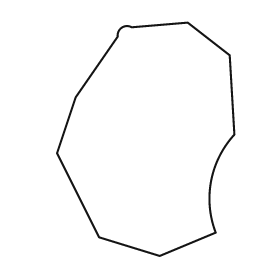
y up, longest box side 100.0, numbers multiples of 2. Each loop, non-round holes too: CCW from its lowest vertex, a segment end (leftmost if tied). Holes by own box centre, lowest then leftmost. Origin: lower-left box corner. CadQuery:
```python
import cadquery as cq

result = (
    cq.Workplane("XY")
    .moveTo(44.0, 0.0)
    .lineTo(68.0, 10.0)
    .threePointArc((66.0, 32.0), (76.0, 52.0))
    .lineTo(74.0, 86.0)
    .lineTo(56.0, 100.0)
    .lineTo(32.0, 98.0)
    .threePointArc((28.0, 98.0), (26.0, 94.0))
    .lineTo(8.0, 68.0)
    .lineTo(0.0, 44.0)
    .lineTo(18.0, 8.0)
    .close()
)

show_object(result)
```